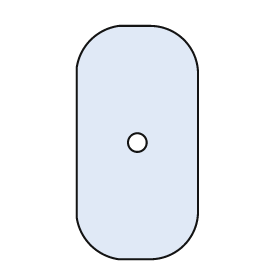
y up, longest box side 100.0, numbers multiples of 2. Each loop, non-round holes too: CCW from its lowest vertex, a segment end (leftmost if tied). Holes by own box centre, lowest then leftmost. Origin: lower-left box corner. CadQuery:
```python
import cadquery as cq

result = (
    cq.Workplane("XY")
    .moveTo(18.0, 0.0)
    .lineTo(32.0, 0.0)
    .threePointArc((46.0, 6.0), (52.0, 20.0))
    .lineTo(52.0, 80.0)
    .threePointArc((46.0, 94.0), (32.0, 100.0))
    .lineTo(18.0, 100.0)
    .threePointArc((6.0, 94.0), (0.0, 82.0))
    .lineTo(0.0, 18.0)
    .threePointArc((6.0, 6.0), (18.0, 0.0))
    .close()
    .moveTo(26.0, 50.0)
    .circle(4.0)
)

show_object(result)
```